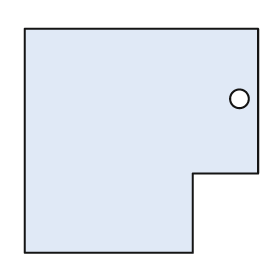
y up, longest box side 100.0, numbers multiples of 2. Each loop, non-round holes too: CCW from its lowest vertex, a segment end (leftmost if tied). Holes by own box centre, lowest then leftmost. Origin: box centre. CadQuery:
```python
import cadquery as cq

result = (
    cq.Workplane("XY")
    .moveTo(-50.0, -48.0)
    .lineTo(22.0, -48.0)
    .lineTo(22.0, -14.0)
    .lineTo(50.0, -14.0)
    .lineTo(50.0, 48.0)
    .lineTo(-50.0, 48.0)
    .close()
    .moveTo(42.0, 18.0)
    .circle(4.0)
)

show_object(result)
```